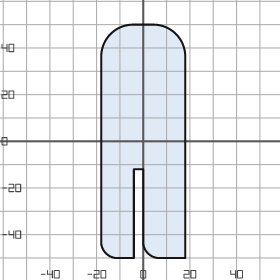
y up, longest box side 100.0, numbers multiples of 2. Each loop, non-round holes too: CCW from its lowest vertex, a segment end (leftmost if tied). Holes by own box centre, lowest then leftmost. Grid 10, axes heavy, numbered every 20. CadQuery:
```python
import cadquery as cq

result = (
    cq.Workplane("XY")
    .moveTo(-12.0, -50.0)
    .lineTo(-4.0, -50.0)
    .lineTo(-4.0, -12.0)
    .lineTo(0.0, -12.0)
    .lineTo(0.0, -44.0)
    .threePointArc((2.0, -48.0), (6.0, -50.0))
    .lineTo(18.0, -50.0)
    .lineTo(18.0, 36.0)
    .threePointArc((14.0, 46.0), (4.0, 50.0))
    .lineTo(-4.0, 50.0)
    .threePointArc((-14.0, 46.0), (-18.0, 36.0))
    .lineTo(-18.0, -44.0)
    .threePointArc((-16.0, -48.0), (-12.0, -50.0))
    .close()
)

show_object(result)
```